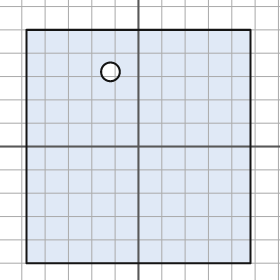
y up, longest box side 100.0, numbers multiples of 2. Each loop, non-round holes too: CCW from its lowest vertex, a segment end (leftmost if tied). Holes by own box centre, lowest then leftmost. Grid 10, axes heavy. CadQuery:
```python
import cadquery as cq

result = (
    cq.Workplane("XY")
    .moveTo(-48.0, -50.0)
    .lineTo(48.0, -50.0)
    .lineTo(48.0, 50.0)
    .lineTo(-48.0, 50.0)
    .close()
    .moveTo(-12.0, 32.0)
    .circle(4.0)
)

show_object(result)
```